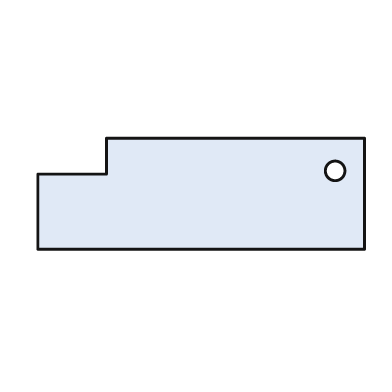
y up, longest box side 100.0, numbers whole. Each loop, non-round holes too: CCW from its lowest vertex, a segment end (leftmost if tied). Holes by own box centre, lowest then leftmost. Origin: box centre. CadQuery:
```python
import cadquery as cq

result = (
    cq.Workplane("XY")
    .moveTo(-50.0, -17.0)
    .lineTo(50.0, -17.0)
    .lineTo(50.0, 17.0)
    .lineTo(-29.0, 17.0)
    .lineTo(-29.0, 6.0)
    .lineTo(-50.0, 6.0)
    .close()
    .moveTo(41.0, 7.0)
    .circle(3.0)
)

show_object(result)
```